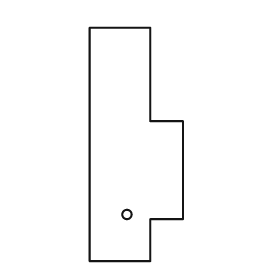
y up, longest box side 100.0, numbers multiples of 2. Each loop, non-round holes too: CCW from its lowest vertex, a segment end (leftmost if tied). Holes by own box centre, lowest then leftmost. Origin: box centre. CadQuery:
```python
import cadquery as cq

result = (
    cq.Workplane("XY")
    .moveTo(-20.0, -50.0)
    .lineTo(6.0, -50.0)
    .lineTo(6.0, -32.0)
    .lineTo(20.0, -32.0)
    .lineTo(20.0, 10.0)
    .lineTo(6.0, 10.0)
    .lineTo(6.0, 50.0)
    .lineTo(-20.0, 50.0)
    .close()
    .moveTo(-4.0, -30.0)
    .circle(2.0)
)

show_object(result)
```